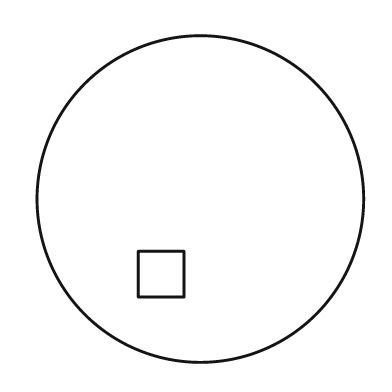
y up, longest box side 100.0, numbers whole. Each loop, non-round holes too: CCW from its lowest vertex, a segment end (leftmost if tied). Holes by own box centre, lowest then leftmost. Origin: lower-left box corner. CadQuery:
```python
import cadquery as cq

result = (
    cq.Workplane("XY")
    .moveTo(50.0, 50.0)
    .circle(50.0)
    .moveTo(31.0, 20.0)
    .lineTo(45.0, 20.0)
    .lineTo(45.0, 34.0)
    .lineTo(31.0, 34.0)
    .close()
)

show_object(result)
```